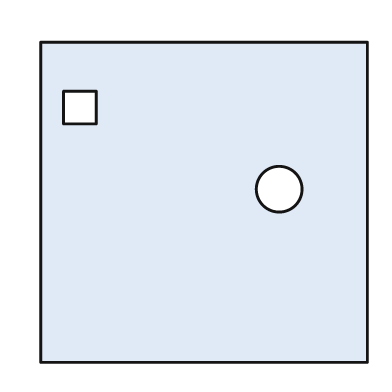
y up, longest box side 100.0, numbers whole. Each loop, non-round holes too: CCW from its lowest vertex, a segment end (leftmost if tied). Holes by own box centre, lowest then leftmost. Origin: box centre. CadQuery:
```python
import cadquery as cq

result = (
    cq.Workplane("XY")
    .moveTo(-50.0, -49.0)
    .lineTo(50.0, -49.0)
    .lineTo(50.0, 49.0)
    .lineTo(-50.0, 49.0)
    .close()
    .moveTo(23.0, 4.0)
    .circle(7.0)
    .moveTo(-43.0, 24.0)
    .lineTo(-33.0, 24.0)
    .lineTo(-33.0, 34.0)
    .lineTo(-43.0, 34.0)
    .close()
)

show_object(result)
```